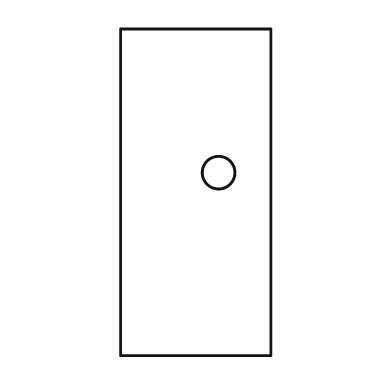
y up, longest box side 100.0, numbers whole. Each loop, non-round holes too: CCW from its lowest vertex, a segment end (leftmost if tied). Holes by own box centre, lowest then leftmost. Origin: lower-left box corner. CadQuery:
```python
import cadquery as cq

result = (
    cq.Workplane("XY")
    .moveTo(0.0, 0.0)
    .lineTo(46.0, 0.0)
    .lineTo(46.0, 100.0)
    .lineTo(0.0, 100.0)
    .close()
    .moveTo(30.0, 56.0)
    .circle(5.0)
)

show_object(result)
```